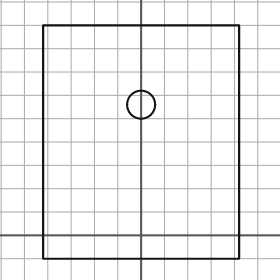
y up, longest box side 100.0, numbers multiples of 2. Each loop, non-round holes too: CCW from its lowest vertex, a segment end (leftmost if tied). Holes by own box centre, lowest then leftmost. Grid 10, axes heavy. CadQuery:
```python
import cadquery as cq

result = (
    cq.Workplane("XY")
    .moveTo(-42.0, -10.0)
    .lineTo(42.0, -10.0)
    .lineTo(42.0, 90.0)
    .lineTo(-42.0, 90.0)
    .close()
    .moveTo(0.0, 56.0)
    .circle(6.0)
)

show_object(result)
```